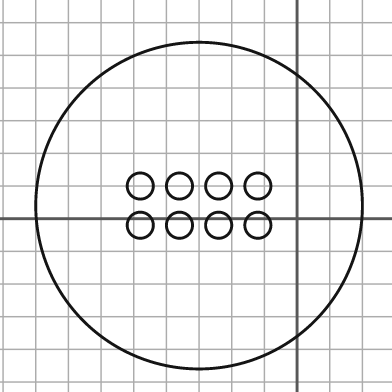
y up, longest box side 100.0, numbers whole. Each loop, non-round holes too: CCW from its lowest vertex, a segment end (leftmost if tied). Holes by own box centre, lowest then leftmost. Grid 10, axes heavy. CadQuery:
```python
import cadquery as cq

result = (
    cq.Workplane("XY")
    .moveTo(-30.0, 4.0)
    .circle(50.0)
    .moveTo(-48.0, -2.0)
    .circle(4.0)
    .moveTo(-36.0, -2.0)
    .circle(4.0)
    .moveTo(-24.0, -2.0)
    .circle(4.0)
    .moveTo(-12.0, -2.0)
    .circle(4.0)
    .moveTo(-48.0, 10.0)
    .circle(4.0)
    .moveTo(-36.0, 10.0)
    .circle(4.0)
    .moveTo(-24.0, 10.0)
    .circle(4.0)
    .moveTo(-12.0, 10.0)
    .circle(4.0)
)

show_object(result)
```